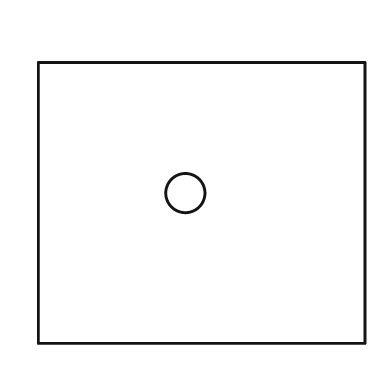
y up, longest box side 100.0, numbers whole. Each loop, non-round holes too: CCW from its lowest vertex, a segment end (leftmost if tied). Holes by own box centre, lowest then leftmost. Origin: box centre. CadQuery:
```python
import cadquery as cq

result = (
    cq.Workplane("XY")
    .moveTo(-50.0, -43.0)
    .lineTo(50.0, -43.0)
    .lineTo(50.0, 43.0)
    .lineTo(-50.0, 43.0)
    .close()
    .moveTo(-5.0, 3.0)
    .circle(6.0)
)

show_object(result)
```